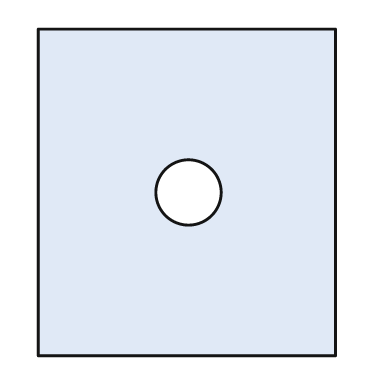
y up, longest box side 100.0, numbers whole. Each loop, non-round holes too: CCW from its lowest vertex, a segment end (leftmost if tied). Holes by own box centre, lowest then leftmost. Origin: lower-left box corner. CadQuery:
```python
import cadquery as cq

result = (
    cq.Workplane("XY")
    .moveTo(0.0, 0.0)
    .lineTo(91.0, 0.0)
    .lineTo(91.0, 100.0)
    .lineTo(0.0, 100.0)
    .close()
    .moveTo(46.0, 50.0)
    .circle(10.0)
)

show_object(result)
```